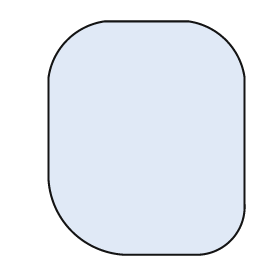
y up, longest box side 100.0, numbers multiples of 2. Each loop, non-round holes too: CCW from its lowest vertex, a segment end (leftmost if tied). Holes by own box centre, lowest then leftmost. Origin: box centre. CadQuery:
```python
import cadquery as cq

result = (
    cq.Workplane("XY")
    .moveTo(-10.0, -50.0)
    .lineTo(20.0, -50.0)
    .threePointArc((36.0, -44.0), (42.0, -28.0))
    .lineTo(42.0, 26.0)
    .threePointArc((34.0, 42.0), (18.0, 50.0))
    .lineTo(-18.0, 50.0)
    .threePointArc((-34.0, 42.0), (-42.0, 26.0))
    .lineTo(-42.0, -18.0)
    .threePointArc((-32.0, -40.0), (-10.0, -50.0))
    .close()
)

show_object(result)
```